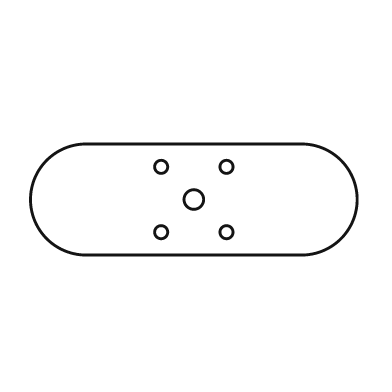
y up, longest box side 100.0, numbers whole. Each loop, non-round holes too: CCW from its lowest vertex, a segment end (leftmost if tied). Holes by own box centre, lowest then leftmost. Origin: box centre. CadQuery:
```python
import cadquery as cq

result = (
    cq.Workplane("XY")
    .moveTo(-33.0, -17.0)
    .lineTo(33.0, -17.0)
    .threePointArc((50.0, 0.0), (33.0, 17.0))
    .lineTo(-33.0, 17.0)
    .threePointArc((-50.0, 0.0), (-33.0, -17.0))
    .close()
    .moveTo(-10.0, -10.0)
    .circle(2.0)
    .moveTo(10.0, -10.0)
    .circle(2.0)
    .moveTo(0.0, 0.0)
    .circle(3.0)
    .moveTo(-10.0, 10.0)
    .circle(2.0)
    .moveTo(10.0, 10.0)
    .circle(2.0)
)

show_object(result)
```